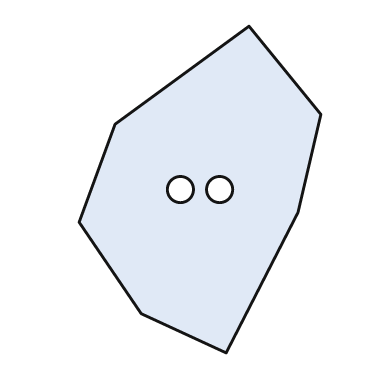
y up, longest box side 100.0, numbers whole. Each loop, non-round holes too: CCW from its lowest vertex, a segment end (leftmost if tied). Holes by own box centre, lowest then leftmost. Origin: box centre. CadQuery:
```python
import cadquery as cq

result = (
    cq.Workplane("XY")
    .moveTo(8.0, -50.0)
    .lineTo(30.0, -7.0)
    .lineTo(37.0, 23.0)
    .lineTo(15.0, 50.0)
    .lineTo(-26.0, 20.0)
    .lineTo(-37.0, -10.0)
    .lineTo(-18.0, -38.0)
    .close()
    .moveTo(-6.0, 0.0)
    .circle(4.0)
    .moveTo(6.0, 0.0)
    .circle(4.0)
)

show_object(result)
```